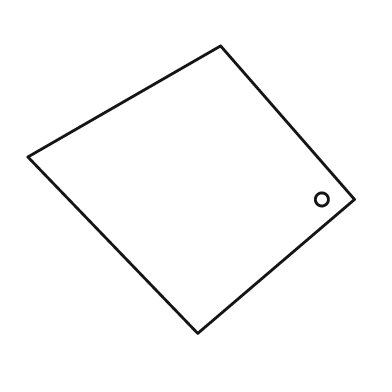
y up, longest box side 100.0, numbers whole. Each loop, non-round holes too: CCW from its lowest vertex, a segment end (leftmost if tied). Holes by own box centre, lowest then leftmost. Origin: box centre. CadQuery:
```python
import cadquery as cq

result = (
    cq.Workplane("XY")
    .moveTo(2.0, -44.0)
    .lineTo(50.0, -3.0)
    .lineTo(9.0, 44.0)
    .lineTo(-50.0, 10.0)
    .close()
    .moveTo(40.0, -3.0)
    .circle(2.0)
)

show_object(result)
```